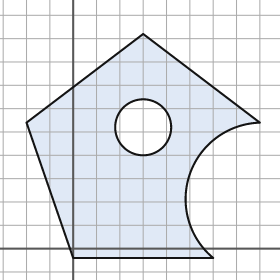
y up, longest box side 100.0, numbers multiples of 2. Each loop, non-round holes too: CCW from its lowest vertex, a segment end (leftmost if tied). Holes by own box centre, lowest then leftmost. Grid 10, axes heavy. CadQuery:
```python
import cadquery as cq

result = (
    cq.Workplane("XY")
    .moveTo(0.0, -4.0)
    .lineTo(60.0, -4.0)
    .threePointArc((50.0, 32.0), (80.0, 54.0))
    .lineTo(30.0, 92.0)
    .lineTo(-20.0, 54.0)
    .close()
    .moveTo(30.0, 52.0)
    .circle(12.0)
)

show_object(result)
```